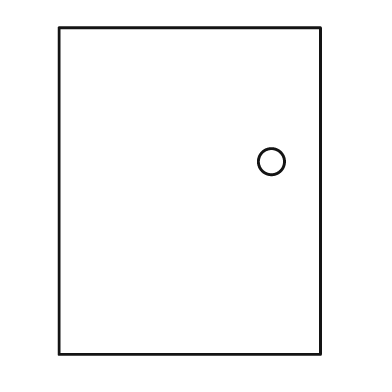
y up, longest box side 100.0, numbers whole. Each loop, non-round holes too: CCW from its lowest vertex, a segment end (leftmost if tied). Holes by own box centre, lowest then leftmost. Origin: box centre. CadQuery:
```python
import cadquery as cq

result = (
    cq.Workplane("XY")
    .moveTo(-40.0, -50.0)
    .lineTo(40.0, -50.0)
    .lineTo(40.0, 50.0)
    .lineTo(-40.0, 50.0)
    .close()
    .moveTo(25.0, 9.0)
    .circle(4.0)
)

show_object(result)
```